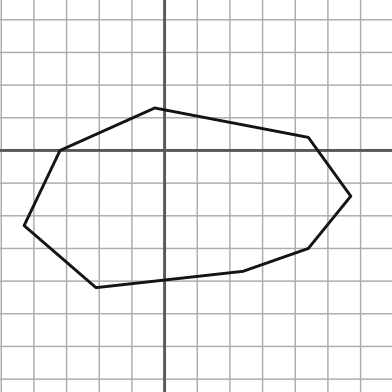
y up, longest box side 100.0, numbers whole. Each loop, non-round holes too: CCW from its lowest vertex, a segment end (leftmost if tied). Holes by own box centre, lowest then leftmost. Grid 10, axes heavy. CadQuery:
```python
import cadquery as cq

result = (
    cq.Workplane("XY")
    .moveTo(-21.0, -42.0)
    .lineTo(24.0, -37.0)
    .lineTo(44.0, -30.0)
    .lineTo(57.0, -14.0)
    .lineTo(44.0, 4.0)
    .lineTo(-3.0, 13.0)
    .lineTo(-32.0, 0.0)
    .lineTo(-43.0, -23.0)
    .close()
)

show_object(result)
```